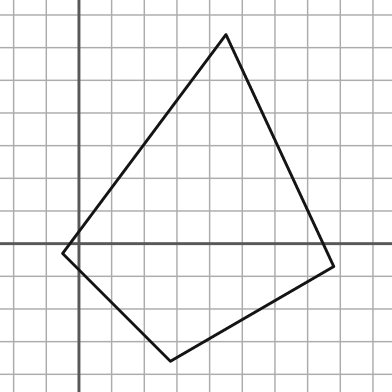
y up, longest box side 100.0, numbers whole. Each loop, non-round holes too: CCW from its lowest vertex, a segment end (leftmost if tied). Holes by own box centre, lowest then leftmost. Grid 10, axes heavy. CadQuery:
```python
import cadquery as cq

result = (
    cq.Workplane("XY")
    .moveTo(28.0, -36.0)
    .lineTo(78.0, -7.0)
    .lineTo(45.0, 64.0)
    .lineTo(-5.0, -3.0)
    .close()
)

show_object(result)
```